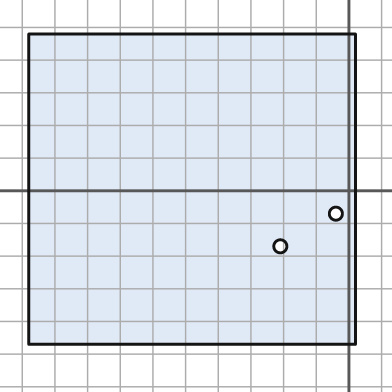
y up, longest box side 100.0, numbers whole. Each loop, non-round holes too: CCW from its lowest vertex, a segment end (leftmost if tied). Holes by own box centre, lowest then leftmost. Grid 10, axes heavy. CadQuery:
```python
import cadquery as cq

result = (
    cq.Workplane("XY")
    .moveTo(-98.0, -47.0)
    .lineTo(2.0, -47.0)
    .lineTo(2.0, 48.0)
    .lineTo(-98.0, 48.0)
    .close()
    .moveTo(-21.0, -17.0)
    .circle(2.0)
    .moveTo(-4.0, -7.0)
    .circle(2.0)
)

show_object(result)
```